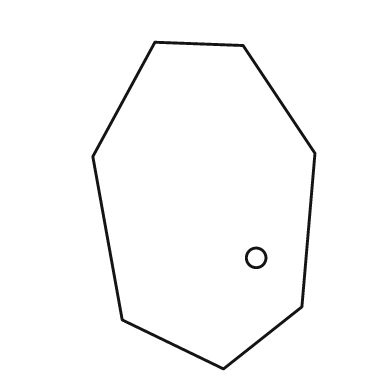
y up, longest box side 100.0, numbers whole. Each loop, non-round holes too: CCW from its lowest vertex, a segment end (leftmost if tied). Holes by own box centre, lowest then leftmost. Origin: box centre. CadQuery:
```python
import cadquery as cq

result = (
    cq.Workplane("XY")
    .moveTo(6.0, -50.0)
    .lineTo(30.0, -31.0)
    .lineTo(34.0, 16.0)
    .lineTo(12.0, 49.0)
    .lineTo(-15.0, 50.0)
    .lineTo(-34.0, 15.0)
    .lineTo(-25.0, -35.0)
    .close()
    .moveTo(16.0, -16.0)
    .circle(3.0)
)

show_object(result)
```